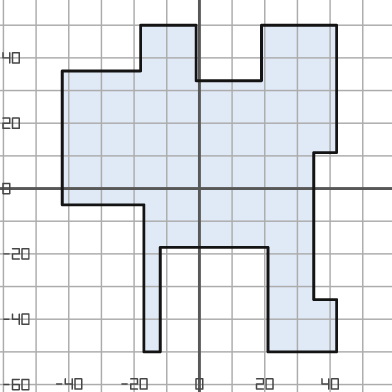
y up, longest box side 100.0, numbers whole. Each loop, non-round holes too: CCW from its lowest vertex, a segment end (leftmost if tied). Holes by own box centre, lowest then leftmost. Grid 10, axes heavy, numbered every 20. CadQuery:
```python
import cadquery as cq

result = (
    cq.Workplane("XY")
    .moveTo(-17.0, -50.0)
    .lineTo(-12.0, -50.0)
    .lineTo(-12.0, -18.0)
    .lineTo(21.0, -18.0)
    .lineTo(21.0, -50.0)
    .lineTo(42.0, -50.0)
    .lineTo(42.0, -34.0)
    .lineTo(35.0, -34.0)
    .lineTo(35.0, 11.0)
    .lineTo(42.0, 11.0)
    .lineTo(42.0, 50.0)
    .lineTo(19.0, 50.0)
    .lineTo(19.0, 33.0)
    .lineTo(-1.0, 33.0)
    .lineTo(-1.0, 50.0)
    .lineTo(-18.0, 50.0)
    .lineTo(-18.0, 36.0)
    .lineTo(-42.0, 36.0)
    .lineTo(-42.0, -5.0)
    .lineTo(-17.0, -5.0)
    .close()
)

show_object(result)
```